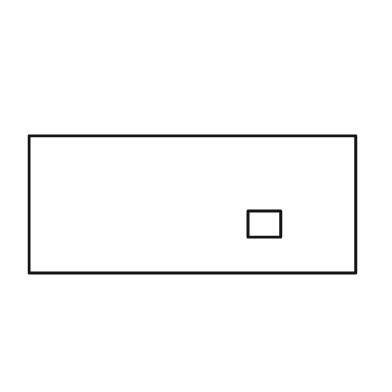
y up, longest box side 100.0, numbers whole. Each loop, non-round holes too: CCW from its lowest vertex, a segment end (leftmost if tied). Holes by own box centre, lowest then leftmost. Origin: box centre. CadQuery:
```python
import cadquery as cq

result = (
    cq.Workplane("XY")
    .moveTo(-50.0, -21.0)
    .lineTo(50.0, -21.0)
    .lineTo(50.0, 21.0)
    .lineTo(-50.0, 21.0)
    .close()
    .moveTo(17.0, -10.0)
    .lineTo(27.0, -10.0)
    .lineTo(27.0, -2.0)
    .lineTo(17.0, -2.0)
    .close()
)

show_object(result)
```